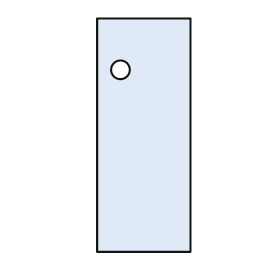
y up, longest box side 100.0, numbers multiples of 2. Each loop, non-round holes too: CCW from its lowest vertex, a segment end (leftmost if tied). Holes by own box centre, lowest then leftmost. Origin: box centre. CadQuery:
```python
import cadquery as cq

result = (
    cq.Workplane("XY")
    .moveTo(-20.0, -50.0)
    .lineTo(20.0, -50.0)
    .lineTo(20.0, 50.0)
    .lineTo(-20.0, 50.0)
    .close()
    .moveTo(-10.0, 28.0)
    .circle(4.0)
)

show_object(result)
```